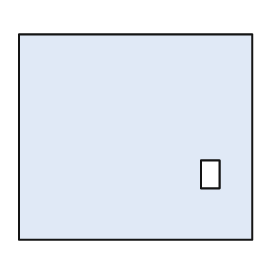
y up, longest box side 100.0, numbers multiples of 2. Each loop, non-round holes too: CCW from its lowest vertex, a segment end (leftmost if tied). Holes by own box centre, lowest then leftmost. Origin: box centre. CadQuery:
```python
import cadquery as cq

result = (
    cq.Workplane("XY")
    .moveTo(-50.0, -44.0)
    .lineTo(50.0, -44.0)
    .lineTo(50.0, 44.0)
    .lineTo(-50.0, 44.0)
    .close()
    .moveTo(28.0, -22.0)
    .lineTo(36.0, -22.0)
    .lineTo(36.0, -10.0)
    .lineTo(28.0, -10.0)
    .close()
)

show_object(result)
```